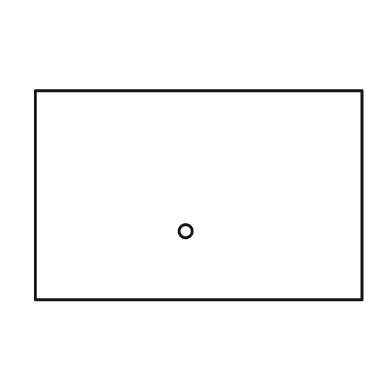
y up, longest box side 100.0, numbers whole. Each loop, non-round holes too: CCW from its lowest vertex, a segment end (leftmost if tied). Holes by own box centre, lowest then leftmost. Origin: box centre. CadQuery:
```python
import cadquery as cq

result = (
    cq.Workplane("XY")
    .moveTo(-50.0, -32.0)
    .lineTo(50.0, -32.0)
    .lineTo(50.0, 32.0)
    .lineTo(-50.0, 32.0)
    .close()
    .moveTo(-4.0, -11.0)
    .circle(2.0)
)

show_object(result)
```